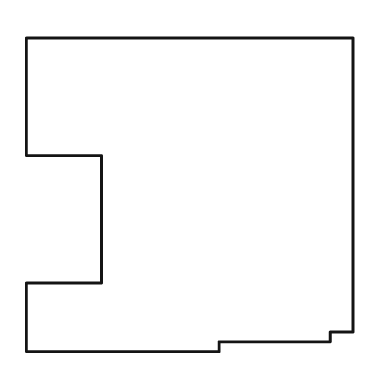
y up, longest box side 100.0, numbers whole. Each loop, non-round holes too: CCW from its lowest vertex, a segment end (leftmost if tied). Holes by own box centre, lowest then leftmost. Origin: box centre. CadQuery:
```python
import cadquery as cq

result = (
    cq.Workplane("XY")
    .moveTo(-50.0, -48.0)
    .lineTo(9.0, -48.0)
    .lineTo(9.0, -45.0)
    .lineTo(43.0, -45.0)
    .lineTo(43.0, -42.0)
    .lineTo(50.0, -42.0)
    .lineTo(50.0, 48.0)
    .lineTo(-50.0, 48.0)
    .lineTo(-50.0, 12.0)
    .lineTo(-27.0, 12.0)
    .lineTo(-27.0, -27.0)
    .lineTo(-50.0, -27.0)
    .close()
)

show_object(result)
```